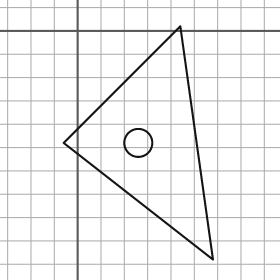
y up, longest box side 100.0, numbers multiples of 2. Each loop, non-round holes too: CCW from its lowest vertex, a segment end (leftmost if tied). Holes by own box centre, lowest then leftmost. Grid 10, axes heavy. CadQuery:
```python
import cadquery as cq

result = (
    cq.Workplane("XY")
    .moveTo(58.0, -98.0)
    .lineTo(44.0, 2.0)
    .lineTo(-6.0, -48.0)
    .close()
    .moveTo(26.0, -48.0)
    .circle(6.0)
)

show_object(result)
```